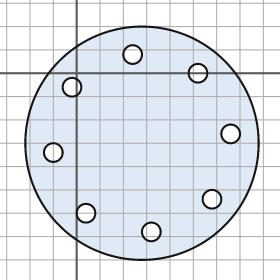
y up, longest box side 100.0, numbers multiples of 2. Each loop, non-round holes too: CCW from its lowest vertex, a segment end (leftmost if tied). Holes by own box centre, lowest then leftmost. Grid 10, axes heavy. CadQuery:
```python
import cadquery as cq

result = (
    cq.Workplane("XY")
    .moveTo(28.0, -30.0)
    .circle(50.0)
    .moveTo(32.0, -68.0)
    .circle(4.0)
    .moveTo(4.0, -60.0)
    .circle(4.0)
    .moveTo(58.0, -54.0)
    .circle(4.0)
    .moveTo(-10.0, -34.0)
    .circle(4.0)
    .moveTo(66.0, -26.0)
    .circle(4.0)
    .moveTo(-2.0, -6.0)
    .circle(4.0)
    .moveTo(52.0, 0.0)
    .circle(4.0)
    .moveTo(24.0, 8.0)
    .circle(4.0)
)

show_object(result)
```